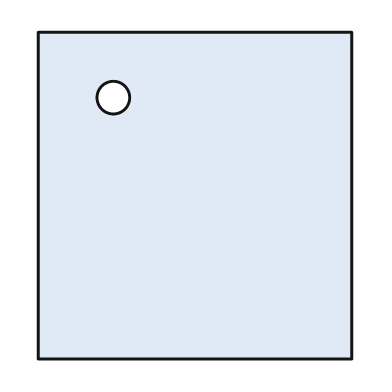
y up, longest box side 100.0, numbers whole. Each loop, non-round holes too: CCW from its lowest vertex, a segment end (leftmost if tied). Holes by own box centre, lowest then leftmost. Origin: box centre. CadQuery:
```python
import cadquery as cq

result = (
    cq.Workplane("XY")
    .moveTo(-48.0, -50.0)
    .lineTo(48.0, -50.0)
    .lineTo(48.0, 50.0)
    .lineTo(-48.0, 50.0)
    .close()
    .moveTo(-25.0, 30.0)
    .circle(5.0)
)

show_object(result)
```